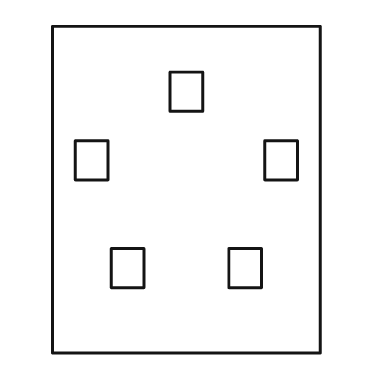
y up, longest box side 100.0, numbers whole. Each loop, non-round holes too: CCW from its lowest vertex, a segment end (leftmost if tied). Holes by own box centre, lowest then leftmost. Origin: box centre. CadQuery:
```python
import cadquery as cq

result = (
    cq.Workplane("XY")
    .moveTo(-41.0, -50.0)
    .lineTo(41.0, -50.0)
    .lineTo(41.0, 50.0)
    .lineTo(-41.0, 50.0)
    .close()
    .moveTo(-23.0, -30.0)
    .lineTo(-13.0, -30.0)
    .lineTo(-13.0, -18.0)
    .lineTo(-23.0, -18.0)
    .close()
    .moveTo(13.0, -30.0)
    .lineTo(23.0, -30.0)
    .lineTo(23.0, -18.0)
    .lineTo(13.0, -18.0)
    .close()
    .moveTo(-34.0, 3.0)
    .lineTo(-24.0, 3.0)
    .lineTo(-24.0, 15.0)
    .lineTo(-34.0, 15.0)
    .close()
    .moveTo(24.0, 3.0)
    .lineTo(34.0, 3.0)
    .lineTo(34.0, 15.0)
    .lineTo(24.0, 15.0)
    .close()
    .moveTo(-5.0, 24.0)
    .lineTo(5.0, 24.0)
    .lineTo(5.0, 36.0)
    .lineTo(-5.0, 36.0)
    .close()
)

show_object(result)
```